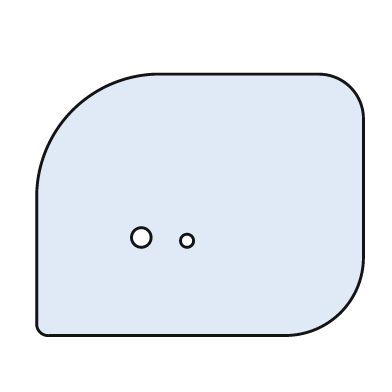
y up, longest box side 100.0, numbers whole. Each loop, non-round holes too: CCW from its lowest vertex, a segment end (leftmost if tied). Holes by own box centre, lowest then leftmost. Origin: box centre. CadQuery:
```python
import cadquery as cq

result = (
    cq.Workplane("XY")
    .moveTo(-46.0, -40.0)
    .lineTo(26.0, -40.0)
    .threePointArc((43.0, -33.0), (50.0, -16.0))
    .lineTo(50.0, 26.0)
    .threePointArc((46.0, 36.0), (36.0, 40.0))
    .lineTo(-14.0, 40.0)
    .threePointArc((-39.0, 29.0), (-50.0, 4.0))
    .lineTo(-50.0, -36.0)
    .threePointArc((-49.0, -39.0), (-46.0, -40.0))
    .close()
    .moveTo(-4.0, -11.0)
    .circle(2.0)
    .moveTo(-18.0, -10.0)
    .circle(3.0)
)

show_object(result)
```